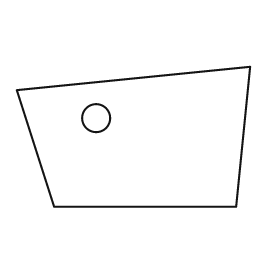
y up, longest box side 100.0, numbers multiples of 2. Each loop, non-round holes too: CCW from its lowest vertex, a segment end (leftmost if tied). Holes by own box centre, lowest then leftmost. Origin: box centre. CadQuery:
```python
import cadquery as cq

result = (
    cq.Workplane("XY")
    .moveTo(-34.0, -30.0)
    .lineTo(44.0, -30.0)
    .lineTo(50.0, 30.0)
    .lineTo(-50.0, 20.0)
    .close()
    .moveTo(-16.0, 8.0)
    .circle(6.0)
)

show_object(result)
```